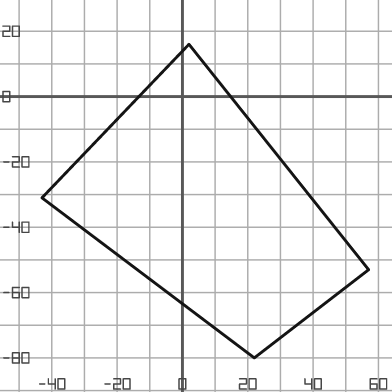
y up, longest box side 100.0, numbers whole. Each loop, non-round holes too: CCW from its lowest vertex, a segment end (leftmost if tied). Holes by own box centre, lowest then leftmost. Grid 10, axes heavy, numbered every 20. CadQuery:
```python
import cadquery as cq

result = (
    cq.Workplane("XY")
    .moveTo(22.0, -80.0)
    .lineTo(57.0, -53.0)
    .lineTo(2.0, 16.0)
    .lineTo(-43.0, -31.0)
    .close()
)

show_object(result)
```